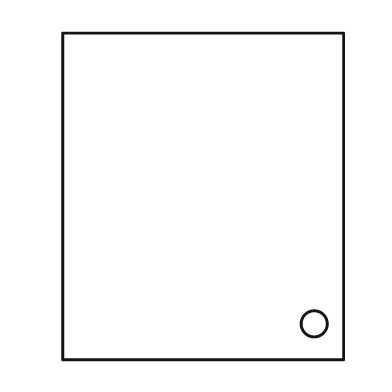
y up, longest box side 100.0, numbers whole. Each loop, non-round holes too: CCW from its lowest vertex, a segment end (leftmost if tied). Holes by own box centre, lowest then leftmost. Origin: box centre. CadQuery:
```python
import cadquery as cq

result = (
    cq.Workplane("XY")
    .moveTo(-43.0, -50.0)
    .lineTo(43.0, -50.0)
    .lineTo(43.0, 50.0)
    .lineTo(-43.0, 50.0)
    .close()
    .moveTo(34.0, -39.0)
    .circle(4.0)
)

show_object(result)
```